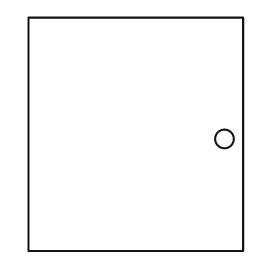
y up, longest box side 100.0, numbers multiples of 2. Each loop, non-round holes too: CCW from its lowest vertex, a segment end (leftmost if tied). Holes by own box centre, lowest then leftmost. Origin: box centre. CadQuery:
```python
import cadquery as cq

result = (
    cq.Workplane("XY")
    .moveTo(-46.0, -50.0)
    .lineTo(46.0, -50.0)
    .lineTo(46.0, 50.0)
    .lineTo(-46.0, 50.0)
    .close()
    .moveTo(38.0, -2.0)
    .circle(4.0)
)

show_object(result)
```